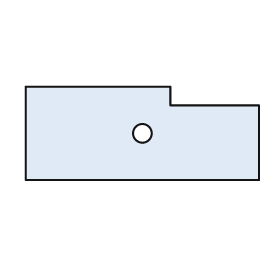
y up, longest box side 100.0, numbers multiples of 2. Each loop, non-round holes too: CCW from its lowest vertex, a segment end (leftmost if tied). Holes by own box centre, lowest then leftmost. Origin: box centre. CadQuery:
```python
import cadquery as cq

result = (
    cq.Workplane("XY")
    .moveTo(-50.0, -20.0)
    .lineTo(50.0, -20.0)
    .lineTo(50.0, 12.0)
    .lineTo(12.0, 12.0)
    .lineTo(12.0, 20.0)
    .lineTo(-50.0, 20.0)
    .close()
    .moveTo(0.0, 0.0)
    .circle(4.0)
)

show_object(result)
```